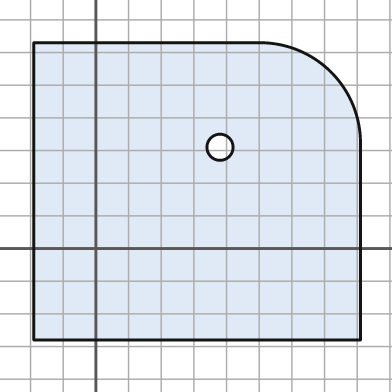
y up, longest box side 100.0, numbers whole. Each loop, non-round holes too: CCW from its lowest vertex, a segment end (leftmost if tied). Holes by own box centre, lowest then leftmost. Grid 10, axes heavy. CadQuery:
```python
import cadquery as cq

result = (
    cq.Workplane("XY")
    .moveTo(-19.0, -28.0)
    .lineTo(81.0, -28.0)
    .lineTo(81.0, 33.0)
    .threePointArc((72.0, 54.0), (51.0, 63.0))
    .lineTo(-19.0, 63.0)
    .close()
    .moveTo(38.0, 31.0)
    .circle(4.0)
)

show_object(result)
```